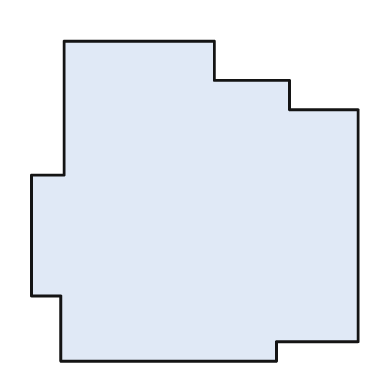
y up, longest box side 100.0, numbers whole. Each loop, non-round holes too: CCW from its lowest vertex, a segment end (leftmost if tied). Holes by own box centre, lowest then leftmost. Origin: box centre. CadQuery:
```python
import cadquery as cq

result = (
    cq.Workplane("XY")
    .moveTo(-41.0, -49.0)
    .lineTo(25.0, -49.0)
    .lineTo(25.0, -43.0)
    .lineTo(50.0, -43.0)
    .lineTo(50.0, 28.0)
    .lineTo(29.0, 28.0)
    .lineTo(29.0, 37.0)
    .lineTo(6.0, 37.0)
    .lineTo(6.0, 49.0)
    .lineTo(-40.0, 49.0)
    .lineTo(-40.0, 8.0)
    .lineTo(-50.0, 8.0)
    .lineTo(-50.0, -29.0)
    .lineTo(-41.0, -29.0)
    .close()
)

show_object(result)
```